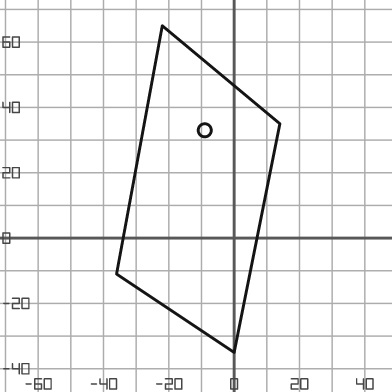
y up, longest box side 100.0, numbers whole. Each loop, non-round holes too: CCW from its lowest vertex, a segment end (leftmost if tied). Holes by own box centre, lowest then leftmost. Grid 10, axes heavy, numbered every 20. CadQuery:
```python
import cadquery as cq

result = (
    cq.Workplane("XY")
    .moveTo(0.0, -35.0)
    .lineTo(14.0, 35.0)
    .lineTo(-22.0, 65.0)
    .lineTo(-36.0, -11.0)
    .close()
    .moveTo(-9.0, 33.0)
    .circle(2.0)
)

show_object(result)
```